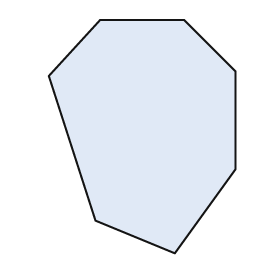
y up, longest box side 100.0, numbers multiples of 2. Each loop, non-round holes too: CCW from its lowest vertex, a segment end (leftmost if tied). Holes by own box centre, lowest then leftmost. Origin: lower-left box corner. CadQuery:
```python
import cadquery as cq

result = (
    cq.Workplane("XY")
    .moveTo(54.0, 0.0)
    .lineTo(80.0, 36.0)
    .lineTo(80.0, 78.0)
    .lineTo(58.0, 100.0)
    .lineTo(22.0, 100.0)
    .lineTo(0.0, 76.0)
    .lineTo(20.0, 14.0)
    .close()
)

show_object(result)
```